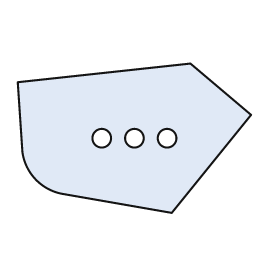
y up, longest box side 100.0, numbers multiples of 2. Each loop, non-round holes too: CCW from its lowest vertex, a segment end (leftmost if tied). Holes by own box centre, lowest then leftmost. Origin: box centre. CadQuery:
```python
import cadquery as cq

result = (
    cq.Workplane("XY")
    .moveTo(16.0, -32.0)
    .lineTo(50.0, 10.0)
    .lineTo(24.0, 32.0)
    .lineTo(-50.0, 24.0)
    .lineTo(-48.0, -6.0)
    .threePointArc((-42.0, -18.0), (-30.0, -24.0))
    .close()
    .moveTo(-14.0, 0.0)
    .circle(4.0)
    .moveTo(0.0, 0.0)
    .circle(4.0)
    .moveTo(14.0, 0.0)
    .circle(4.0)
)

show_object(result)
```